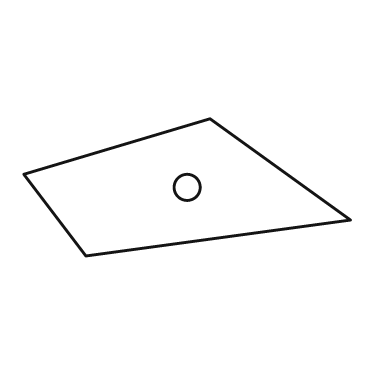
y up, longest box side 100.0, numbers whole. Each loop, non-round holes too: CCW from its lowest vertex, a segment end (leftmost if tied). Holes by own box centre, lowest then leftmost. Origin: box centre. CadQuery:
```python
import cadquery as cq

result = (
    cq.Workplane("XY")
    .moveTo(-31.0, -21.0)
    .lineTo(50.0, -10.0)
    .lineTo(7.0, 21.0)
    .lineTo(-50.0, 4.0)
    .close()
    .moveTo(0.0, 0.0)
    .circle(4.0)
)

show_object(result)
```